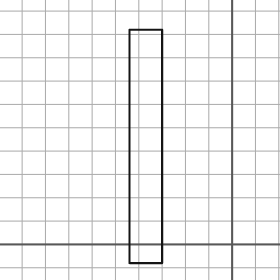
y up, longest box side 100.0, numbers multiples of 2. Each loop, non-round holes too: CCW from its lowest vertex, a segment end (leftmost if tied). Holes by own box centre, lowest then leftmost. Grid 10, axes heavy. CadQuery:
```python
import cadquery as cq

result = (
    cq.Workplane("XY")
    .moveTo(-44.0, -8.0)
    .lineTo(-30.0, -8.0)
    .lineTo(-30.0, 92.0)
    .lineTo(-44.0, 92.0)
    .close()
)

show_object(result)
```